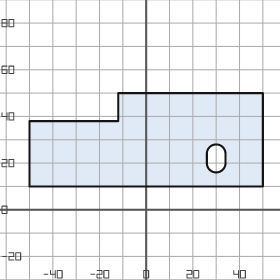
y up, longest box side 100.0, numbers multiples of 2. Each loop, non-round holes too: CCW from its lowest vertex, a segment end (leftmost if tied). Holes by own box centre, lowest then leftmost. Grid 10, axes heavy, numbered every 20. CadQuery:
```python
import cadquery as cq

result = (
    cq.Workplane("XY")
    .moveTo(-50.0, 10.0)
    .lineTo(50.0, 10.0)
    .lineTo(50.0, 50.0)
    .lineTo(-12.0, 50.0)
    .lineTo(-12.0, 38.0)
    .lineTo(-50.0, 38.0)
    .close()
    .moveTo(26.0, 20.0)
    .threePointArc((30.0, 16.0), (34.0, 20.0))
    .lineTo(34.0, 24.0)
    .threePointArc((30.0, 28.0), (26.0, 24.0))
    .close()
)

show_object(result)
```